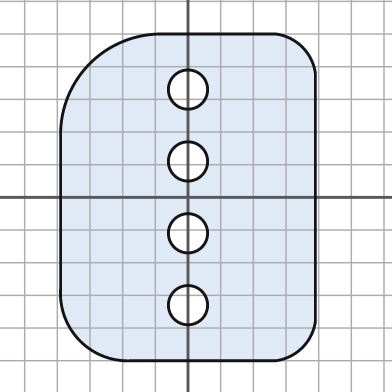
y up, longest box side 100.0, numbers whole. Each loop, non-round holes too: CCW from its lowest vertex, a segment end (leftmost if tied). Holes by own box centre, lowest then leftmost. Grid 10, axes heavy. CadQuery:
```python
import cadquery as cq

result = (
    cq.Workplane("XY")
    .moveTo(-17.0, -50.0)
    .lineTo(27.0, -50.0)
    .threePointArc((35.0, -46.0), (39.0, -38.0))
    .lineTo(39.0, 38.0)
    .threePointArc((35.0, 46.0), (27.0, 50.0))
    .lineTo(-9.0, 50.0)
    .threePointArc((-30.0, 41.0), (-39.0, 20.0))
    .lineTo(-39.0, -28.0)
    .threePointArc((-33.0, -44.0), (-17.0, -50.0))
    .close()
    .moveTo(0.0, -33.0)
    .circle(6.0)
    .moveTo(0.0, -11.0)
    .circle(6.0)
    .moveTo(0.0, 11.0)
    .circle(6.0)
    .moveTo(0.0, 33.0)
    .circle(6.0)
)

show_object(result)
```